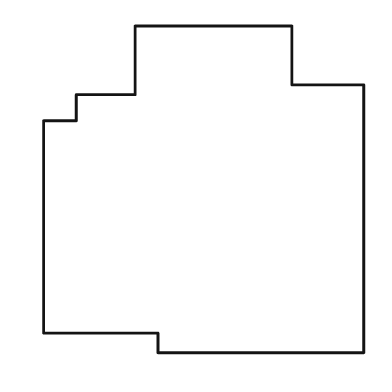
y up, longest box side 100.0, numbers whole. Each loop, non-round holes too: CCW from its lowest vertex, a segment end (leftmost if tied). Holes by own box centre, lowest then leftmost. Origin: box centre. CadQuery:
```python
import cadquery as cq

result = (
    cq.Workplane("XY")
    .moveTo(-14.0, -50.0)
    .lineTo(49.0, -50.0)
    .lineTo(49.0, 32.0)
    .lineTo(27.0, 32.0)
    .lineTo(27.0, 50.0)
    .lineTo(-21.0, 50.0)
    .lineTo(-21.0, 29.0)
    .lineTo(-39.0, 29.0)
    .lineTo(-39.0, 21.0)
    .lineTo(-49.0, 21.0)
    .lineTo(-49.0, -44.0)
    .lineTo(-14.0, -44.0)
    .close()
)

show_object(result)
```